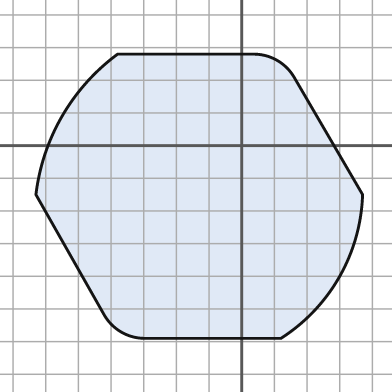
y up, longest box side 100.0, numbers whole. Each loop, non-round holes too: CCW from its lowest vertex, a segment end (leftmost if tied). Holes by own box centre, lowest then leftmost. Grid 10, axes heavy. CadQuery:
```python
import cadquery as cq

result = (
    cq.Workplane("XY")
    .moveTo(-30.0, -59.0)
    .lineTo(12.0, -59.0)
    .threePointArc((30.0, -40.0), (37.0, -15.0))
    .lineTo(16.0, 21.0)
    .threePointArc((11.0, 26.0), (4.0, 28.0))
    .lineTo(-38.0, 28.0)
    .threePointArc((-55.0, 9.0), (-63.0, -15.0))
    .lineTo(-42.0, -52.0)
    .threePointArc((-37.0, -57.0), (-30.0, -59.0))
    .close()
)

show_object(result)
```